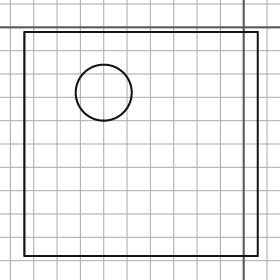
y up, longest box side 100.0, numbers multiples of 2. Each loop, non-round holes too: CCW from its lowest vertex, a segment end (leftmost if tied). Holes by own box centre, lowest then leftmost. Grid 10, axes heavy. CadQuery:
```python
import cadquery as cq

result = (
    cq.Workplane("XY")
    .moveTo(-94.0, -98.0)
    .lineTo(6.0, -98.0)
    .lineTo(6.0, -2.0)
    .lineTo(-94.0, -2.0)
    .close()
    .moveTo(-60.0, -28.0)
    .circle(12.0)
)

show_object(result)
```